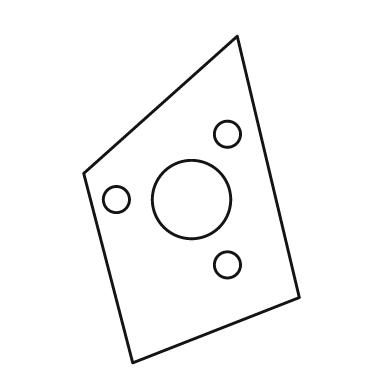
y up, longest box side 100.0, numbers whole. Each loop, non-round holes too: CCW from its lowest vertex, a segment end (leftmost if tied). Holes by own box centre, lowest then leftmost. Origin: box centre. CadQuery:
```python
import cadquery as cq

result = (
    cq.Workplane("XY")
    .moveTo(-18.0, -50.0)
    .lineTo(33.0, -30.0)
    .lineTo(14.0, 50.0)
    .lineTo(-33.0, 8.0)
    .close()
    .moveTo(11.0, -20.0)
    .circle(4.0)
    .moveTo(-23.0, 0.0)
    .circle(4.0)
    .moveTo(0.0, 0.0)
    .circle(12.0)
    .moveTo(11.0, 20.0)
    .circle(4.0)
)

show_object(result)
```